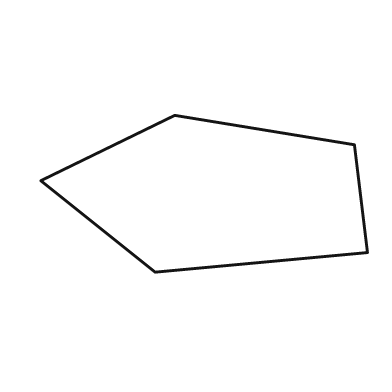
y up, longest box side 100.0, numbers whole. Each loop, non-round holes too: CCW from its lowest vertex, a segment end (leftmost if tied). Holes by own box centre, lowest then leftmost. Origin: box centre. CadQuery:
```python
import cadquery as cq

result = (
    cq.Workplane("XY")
    .moveTo(-15.0, -24.0)
    .lineTo(50.0, -18.0)
    .lineTo(46.0, 15.0)
    .lineTo(-9.0, 24.0)
    .lineTo(-50.0, 4.0)
    .close()
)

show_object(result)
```